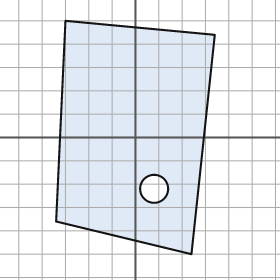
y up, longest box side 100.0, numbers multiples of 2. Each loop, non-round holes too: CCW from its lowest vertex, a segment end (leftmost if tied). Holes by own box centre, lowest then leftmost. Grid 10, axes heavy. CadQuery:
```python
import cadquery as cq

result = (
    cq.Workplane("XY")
    .moveTo(24.0, -50.0)
    .lineTo(34.0, 44.0)
    .lineTo(-30.0, 50.0)
    .lineTo(-34.0, -36.0)
    .close()
    .moveTo(8.0, -22.0)
    .circle(6.0)
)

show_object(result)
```